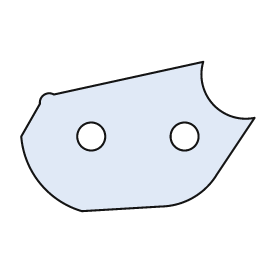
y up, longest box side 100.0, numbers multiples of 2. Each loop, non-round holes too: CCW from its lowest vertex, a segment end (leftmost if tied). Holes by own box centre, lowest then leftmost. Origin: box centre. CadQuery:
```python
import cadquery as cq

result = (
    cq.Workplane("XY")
    .moveTo(-24.0, -32.0)
    .lineTo(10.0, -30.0)
    .threePointArc((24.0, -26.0), (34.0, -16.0))
    .lineTo(50.0, 8.0)
    .threePointArc((32.0, 14.0), (28.0, 32.0))
    .lineTo(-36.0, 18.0)
    .threePointArc((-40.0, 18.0), (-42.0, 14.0))
    .lineTo(-50.0, 0.0)
    .threePointArc((-42.0, -20.0), (-24.0, -32.0))
    .close()
    .moveTo(-20.0, 0.0)
    .circle(6.0)
    .moveTo(20.0, 0.0)
    .circle(6.0)
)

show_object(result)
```